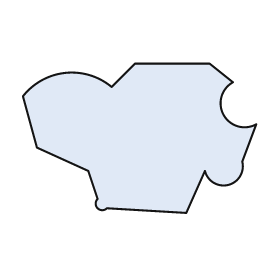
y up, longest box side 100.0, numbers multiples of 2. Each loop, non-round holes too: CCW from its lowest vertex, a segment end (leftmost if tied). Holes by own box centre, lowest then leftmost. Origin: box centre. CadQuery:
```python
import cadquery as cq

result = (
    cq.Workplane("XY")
    .moveTo(20.0, -32.0)
    .lineTo(28.0, -14.0)
    .threePointArc((38.0, -20.0), (44.0, -10.0))
    .lineTo(50.0, 6.0)
    .threePointArc((36.0, 10.0), (40.0, 24.0))
    .lineTo(30.0, 32.0)
    .lineTo(-2.0, 32.0)
    .lineTo(-12.0, 22.0)
    .threePointArc((-32.0, 28.0), (-50.0, 18.0))
    .lineTo(-44.0, -4.0)
    .lineTo(-22.0, -14.0)
    .lineTo(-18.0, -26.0)
    .threePointArc((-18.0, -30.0), (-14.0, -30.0))
    .close()
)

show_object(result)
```